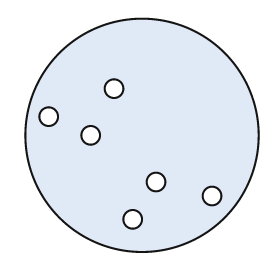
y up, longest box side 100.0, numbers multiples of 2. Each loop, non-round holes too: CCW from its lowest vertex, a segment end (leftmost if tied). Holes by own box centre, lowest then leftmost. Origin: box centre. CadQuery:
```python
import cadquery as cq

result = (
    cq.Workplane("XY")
    .moveTo(0.0, 0.0)
    .circle(50.0)
    .moveTo(-4.0, -36.0)
    .circle(4.0)
    .moveTo(30.0, -26.0)
    .circle(4.0)
    .moveTo(6.0, -20.0)
    .circle(4.0)
    .moveTo(-22.0, 0.0)
    .circle(4.0)
    .moveTo(-40.0, 8.0)
    .circle(4.0)
    .moveTo(-12.0, 20.0)
    .circle(4.0)
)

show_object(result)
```